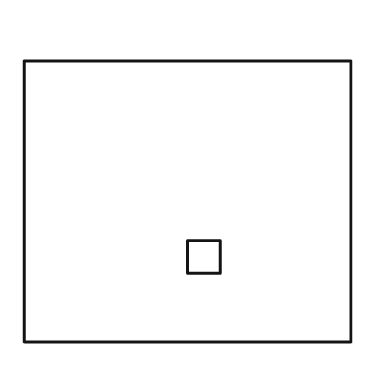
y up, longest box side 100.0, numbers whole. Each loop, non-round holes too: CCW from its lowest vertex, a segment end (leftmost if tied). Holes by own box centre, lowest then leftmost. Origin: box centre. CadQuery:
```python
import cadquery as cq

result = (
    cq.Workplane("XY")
    .moveTo(-50.0, -43.0)
    .lineTo(50.0, -43.0)
    .lineTo(50.0, 43.0)
    .lineTo(-50.0, 43.0)
    .close()
    .moveTo(0.0, -22.0)
    .lineTo(10.0, -22.0)
    .lineTo(10.0, -12.0)
    .lineTo(0.0, -12.0)
    .close()
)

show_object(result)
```